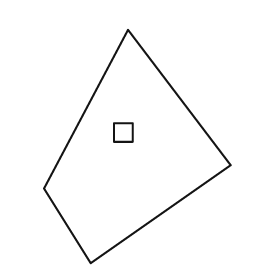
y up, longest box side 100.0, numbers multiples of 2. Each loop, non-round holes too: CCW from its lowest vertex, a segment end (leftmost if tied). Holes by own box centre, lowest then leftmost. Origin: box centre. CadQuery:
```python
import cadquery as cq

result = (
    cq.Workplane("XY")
    .moveTo(-20.0, -50.0)
    .lineTo(40.0, -8.0)
    .lineTo(-4.0, 50.0)
    .lineTo(-40.0, -18.0)
    .close()
    .moveTo(-10.0, 2.0)
    .lineTo(-2.0, 2.0)
    .lineTo(-2.0, 10.0)
    .lineTo(-10.0, 10.0)
    .close()
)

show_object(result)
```